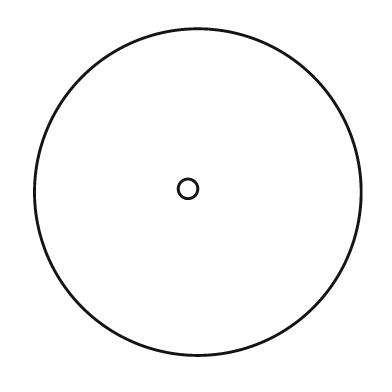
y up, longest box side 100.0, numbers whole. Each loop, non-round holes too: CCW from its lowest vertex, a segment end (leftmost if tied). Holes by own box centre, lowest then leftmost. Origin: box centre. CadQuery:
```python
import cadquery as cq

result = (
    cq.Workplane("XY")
    .moveTo(0.0, 0.0)
    .circle(50.0)
    .moveTo(-3.0, 1.0)
    .circle(3.0)
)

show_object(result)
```